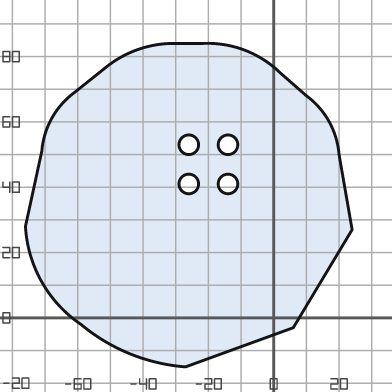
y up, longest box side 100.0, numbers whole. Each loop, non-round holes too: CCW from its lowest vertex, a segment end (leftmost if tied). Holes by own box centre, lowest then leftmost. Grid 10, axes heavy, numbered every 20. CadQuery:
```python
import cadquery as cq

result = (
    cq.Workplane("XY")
    .moveTo(-27.0, -15.0)
    .lineTo(6.0, -3.0)
    .lineTo(24.0, 27.0)
    .lineTo(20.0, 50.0)
    .threePointArc((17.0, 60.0), (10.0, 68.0))
    .lineTo(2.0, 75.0)
    .threePointArc((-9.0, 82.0), (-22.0, 84.0))
    .lineTo(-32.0, 84.0)
    .threePointArc((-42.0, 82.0), (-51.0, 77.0))
    .lineTo(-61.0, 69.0)
    .threePointArc((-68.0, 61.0), (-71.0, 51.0))
    .lineTo(-76.0, 28.0)
    .threePointArc((-71.0, 11.0), (-59.0, -2.0))
    .threePointArc((-44.0, -11.0), (-27.0, -15.0))
    .close()
    .moveTo(-26.0, 41.0)
    .circle(3.0)
    .moveTo(-14.0, 41.0)
    .circle(3.0)
    .moveTo(-26.0, 53.0)
    .circle(3.0)
    .moveTo(-14.0, 53.0)
    .circle(3.0)
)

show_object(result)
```